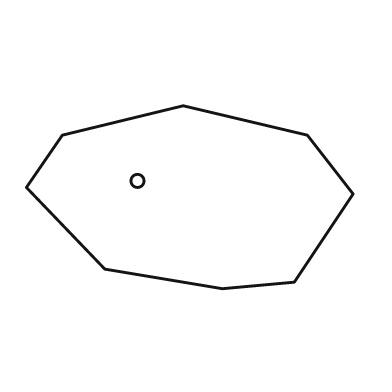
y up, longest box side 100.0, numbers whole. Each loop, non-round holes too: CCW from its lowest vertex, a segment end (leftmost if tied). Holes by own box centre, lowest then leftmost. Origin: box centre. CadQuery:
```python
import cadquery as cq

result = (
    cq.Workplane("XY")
    .moveTo(10.0, -28.0)
    .lineTo(32.0, -26.0)
    .lineTo(50.0, 1.0)
    .lineTo(36.0, 19.0)
    .lineTo(-2.0, 28.0)
    .lineTo(-39.0, 19.0)
    .lineTo(-50.0, 3.0)
    .lineTo(-26.0, -22.0)
    .close()
    .moveTo(-16.0, 5.0)
    .circle(2.0)
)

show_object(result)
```